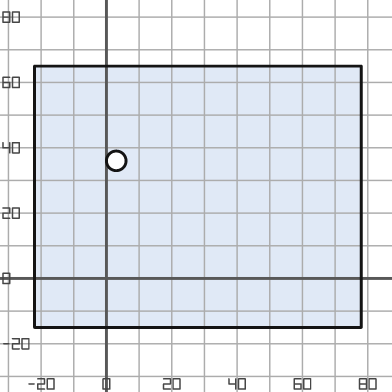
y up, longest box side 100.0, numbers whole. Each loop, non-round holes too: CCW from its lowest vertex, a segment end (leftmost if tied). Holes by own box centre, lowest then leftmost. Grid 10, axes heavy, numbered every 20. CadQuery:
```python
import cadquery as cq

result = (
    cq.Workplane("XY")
    .moveTo(-22.0, -15.0)
    .lineTo(78.0, -15.0)
    .lineTo(78.0, 65.0)
    .lineTo(-22.0, 65.0)
    .close()
    .moveTo(3.0, 36.0)
    .circle(3.0)
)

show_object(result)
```